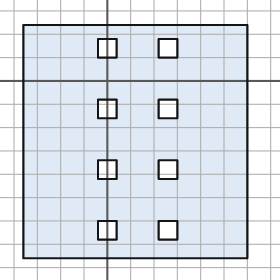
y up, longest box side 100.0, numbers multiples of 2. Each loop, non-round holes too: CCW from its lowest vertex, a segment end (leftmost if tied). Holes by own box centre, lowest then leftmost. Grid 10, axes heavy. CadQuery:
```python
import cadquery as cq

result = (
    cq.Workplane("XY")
    .moveTo(-36.0, -76.0)
    .lineTo(60.0, -76.0)
    .lineTo(60.0, 24.0)
    .lineTo(-36.0, 24.0)
    .close()
    .moveTo(-4.0, -68.0)
    .lineTo(4.0, -68.0)
    .lineTo(4.0, -60.0)
    .lineTo(-4.0, -60.0)
    .close()
    .moveTo(22.0, -68.0)
    .lineTo(30.0, -68.0)
    .lineTo(30.0, -60.0)
    .lineTo(22.0, -60.0)
    .close()
    .moveTo(-4.0, -42.0)
    .lineTo(4.0, -42.0)
    .lineTo(4.0, -34.0)
    .lineTo(-4.0, -34.0)
    .close()
    .moveTo(22.0, -42.0)
    .lineTo(30.0, -42.0)
    .lineTo(30.0, -34.0)
    .lineTo(22.0, -34.0)
    .close()
    .moveTo(-4.0, -16.0)
    .lineTo(4.0, -16.0)
    .lineTo(4.0, -8.0)
    .lineTo(-4.0, -8.0)
    .close()
    .moveTo(22.0, -16.0)
    .lineTo(30.0, -16.0)
    .lineTo(30.0, -8.0)
    .lineTo(22.0, -8.0)
    .close()
    .moveTo(-4.0, 10.0)
    .lineTo(4.0, 10.0)
    .lineTo(4.0, 18.0)
    .lineTo(-4.0, 18.0)
    .close()
    .moveTo(22.0, 10.0)
    .lineTo(30.0, 10.0)
    .lineTo(30.0, 18.0)
    .lineTo(22.0, 18.0)
    .close()
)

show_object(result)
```